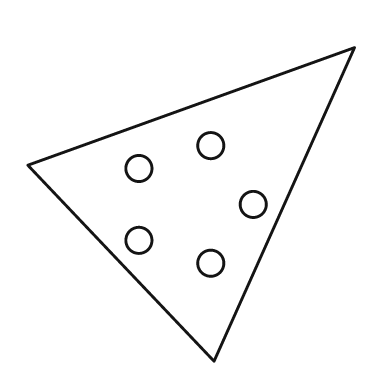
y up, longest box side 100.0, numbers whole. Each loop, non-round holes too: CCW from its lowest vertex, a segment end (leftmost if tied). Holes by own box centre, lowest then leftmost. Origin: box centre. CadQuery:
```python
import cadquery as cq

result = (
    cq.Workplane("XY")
    .moveTo(7.0, -48.0)
    .lineTo(50.0, 48.0)
    .lineTo(-50.0, 12.0)
    .close()
    .moveTo(6.0, -18.0)
    .circle(4.0)
    .moveTo(-16.0, -11.0)
    .circle(4.0)
    .moveTo(19.0, 0.0)
    .circle(4.0)
    .moveTo(-16.0, 11.0)
    .circle(4.0)
    .moveTo(6.0, 18.0)
    .circle(4.0)
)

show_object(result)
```